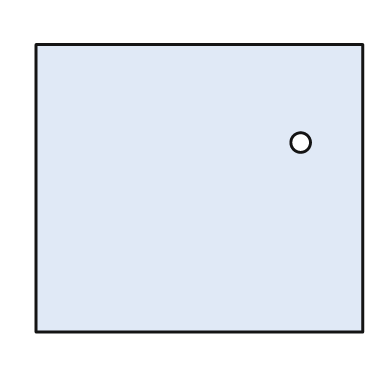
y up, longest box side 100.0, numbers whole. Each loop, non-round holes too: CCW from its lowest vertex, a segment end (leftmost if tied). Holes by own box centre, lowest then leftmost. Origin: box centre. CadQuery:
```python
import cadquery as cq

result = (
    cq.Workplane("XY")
    .moveTo(-50.0, -44.0)
    .lineTo(50.0, -44.0)
    .lineTo(50.0, 44.0)
    .lineTo(-50.0, 44.0)
    .close()
    .moveTo(31.0, 14.0)
    .circle(3.0)
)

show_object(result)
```